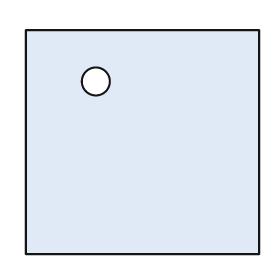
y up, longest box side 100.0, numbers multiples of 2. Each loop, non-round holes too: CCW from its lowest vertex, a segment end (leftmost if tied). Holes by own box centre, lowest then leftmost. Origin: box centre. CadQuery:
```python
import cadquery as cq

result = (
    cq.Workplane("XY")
    .moveTo(-50.0, -48.0)
    .lineTo(50.0, -48.0)
    .lineTo(50.0, 48.0)
    .lineTo(-50.0, 48.0)
    .close()
    .moveTo(-20.0, 26.0)
    .circle(6.0)
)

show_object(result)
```